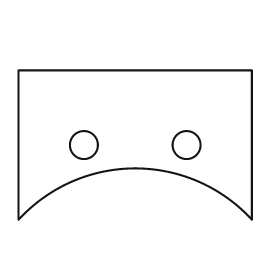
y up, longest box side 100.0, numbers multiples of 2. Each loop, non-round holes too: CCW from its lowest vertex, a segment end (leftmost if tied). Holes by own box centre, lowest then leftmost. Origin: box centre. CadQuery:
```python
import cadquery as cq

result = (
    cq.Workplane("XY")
    .moveTo(-50.0, -32.0)
    .threePointArc((0.0, -10.0), (50.0, -32.0))
    .lineTo(50.0, 32.0)
    .lineTo(-50.0, 32.0)
    .close()
    .moveTo(-22.0, 0.0)
    .circle(6.0)
    .moveTo(22.0, 0.0)
    .circle(6.0)
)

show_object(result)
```